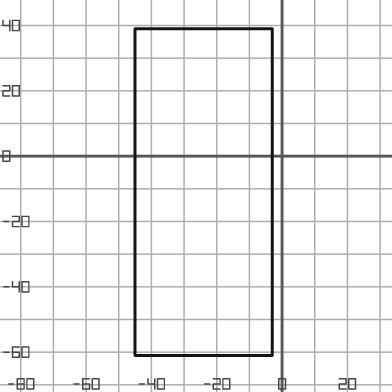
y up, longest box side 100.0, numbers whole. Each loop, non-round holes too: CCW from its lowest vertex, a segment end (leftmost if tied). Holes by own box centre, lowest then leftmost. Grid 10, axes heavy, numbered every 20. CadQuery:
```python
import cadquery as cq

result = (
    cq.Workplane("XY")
    .moveTo(-45.0, -61.0)
    .lineTo(-3.0, -61.0)
    .lineTo(-3.0, 39.0)
    .lineTo(-45.0, 39.0)
    .close()
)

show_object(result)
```